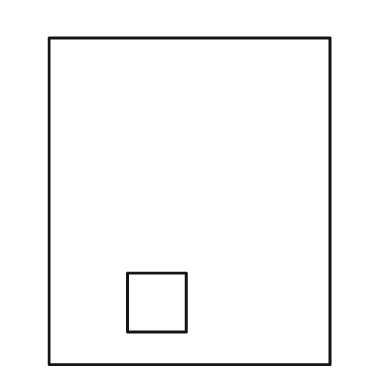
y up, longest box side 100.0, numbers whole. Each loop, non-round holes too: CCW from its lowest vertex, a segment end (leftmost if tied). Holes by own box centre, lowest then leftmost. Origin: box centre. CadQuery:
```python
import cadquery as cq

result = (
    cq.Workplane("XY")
    .moveTo(-43.0, -50.0)
    .lineTo(43.0, -50.0)
    .lineTo(43.0, 50.0)
    .lineTo(-43.0, 50.0)
    .close()
    .moveTo(-19.0, -40.0)
    .lineTo(-1.0, -40.0)
    .lineTo(-1.0, -22.0)
    .lineTo(-19.0, -22.0)
    .close()
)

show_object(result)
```